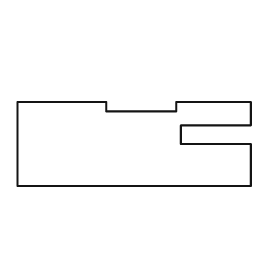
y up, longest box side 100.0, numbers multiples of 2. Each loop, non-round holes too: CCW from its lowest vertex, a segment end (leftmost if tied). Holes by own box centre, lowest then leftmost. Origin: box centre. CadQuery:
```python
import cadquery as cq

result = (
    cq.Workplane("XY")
    .moveTo(-50.0, -18.0)
    .lineTo(50.0, -18.0)
    .lineTo(50.0, 0.0)
    .lineTo(20.0, 0.0)
    .lineTo(20.0, 8.0)
    .lineTo(50.0, 8.0)
    .lineTo(50.0, 18.0)
    .lineTo(18.0, 18.0)
    .lineTo(18.0, 14.0)
    .lineTo(-12.0, 14.0)
    .lineTo(-12.0, 18.0)
    .lineTo(-50.0, 18.0)
    .close()
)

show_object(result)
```